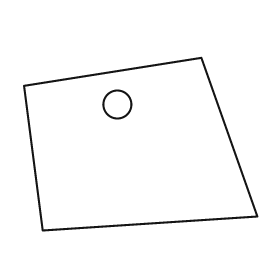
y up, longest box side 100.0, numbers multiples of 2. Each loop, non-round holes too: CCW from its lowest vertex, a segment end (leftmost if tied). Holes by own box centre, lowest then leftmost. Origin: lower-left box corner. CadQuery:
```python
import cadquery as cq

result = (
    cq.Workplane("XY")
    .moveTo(8.0, 0.0)
    .lineTo(100.0, 6.0)
    .lineTo(76.0, 74.0)
    .lineTo(0.0, 62.0)
    .close()
    .moveTo(40.0, 54.0)
    .circle(6.0)
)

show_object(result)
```